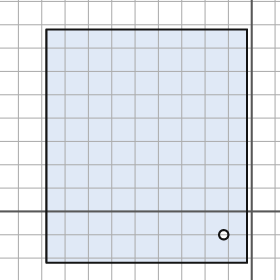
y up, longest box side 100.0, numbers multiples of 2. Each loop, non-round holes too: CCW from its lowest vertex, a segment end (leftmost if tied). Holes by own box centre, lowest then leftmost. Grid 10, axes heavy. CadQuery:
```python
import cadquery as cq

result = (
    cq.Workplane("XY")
    .moveTo(-88.0, -22.0)
    .lineTo(-2.0, -22.0)
    .lineTo(-2.0, 78.0)
    .lineTo(-88.0, 78.0)
    .close()
    .moveTo(-12.0, -10.0)
    .circle(2.0)
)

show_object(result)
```